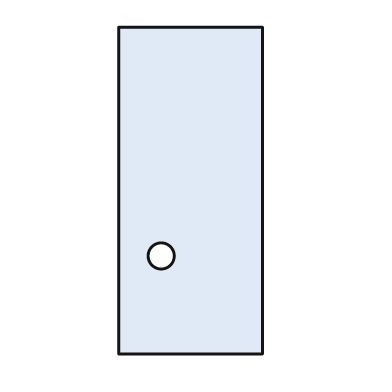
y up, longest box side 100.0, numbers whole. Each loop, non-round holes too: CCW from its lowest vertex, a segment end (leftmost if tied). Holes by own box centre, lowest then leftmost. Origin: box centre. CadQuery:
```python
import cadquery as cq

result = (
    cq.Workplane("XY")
    .moveTo(-22.0, -50.0)
    .lineTo(22.0, -50.0)
    .lineTo(22.0, 50.0)
    .lineTo(-22.0, 50.0)
    .close()
    .moveTo(-9.0, -20.0)
    .circle(4.0)
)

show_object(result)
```